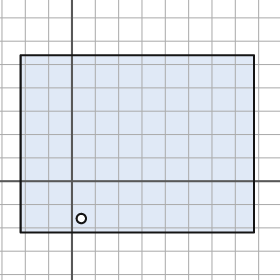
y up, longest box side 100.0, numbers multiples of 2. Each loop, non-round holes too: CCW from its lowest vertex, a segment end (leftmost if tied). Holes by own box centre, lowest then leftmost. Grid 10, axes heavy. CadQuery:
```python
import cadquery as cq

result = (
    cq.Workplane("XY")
    .moveTo(-22.0, -22.0)
    .lineTo(78.0, -22.0)
    .lineTo(78.0, 54.0)
    .lineTo(-22.0, 54.0)
    .close()
    .moveTo(4.0, -16.0)
    .circle(2.0)
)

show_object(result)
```